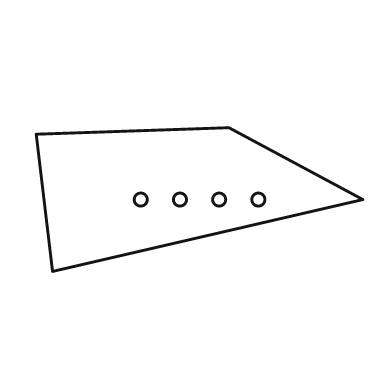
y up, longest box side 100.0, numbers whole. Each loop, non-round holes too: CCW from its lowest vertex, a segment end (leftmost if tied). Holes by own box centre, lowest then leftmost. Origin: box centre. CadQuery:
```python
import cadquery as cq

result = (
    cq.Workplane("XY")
    .moveTo(-45.0, -22.0)
    .lineTo(50.0, 0.0)
    .lineTo(9.0, 22.0)
    .lineTo(-50.0, 20.0)
    .close()
    .moveTo(-18.0, 0.0)
    .circle(2.0)
    .moveTo(-6.0, 0.0)
    .circle(2.0)
    .moveTo(6.0, 0.0)
    .circle(2.0)
    .moveTo(18.0, 0.0)
    .circle(2.0)
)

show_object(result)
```